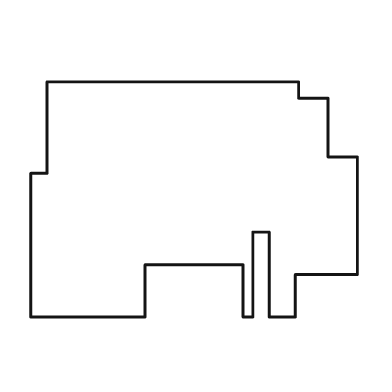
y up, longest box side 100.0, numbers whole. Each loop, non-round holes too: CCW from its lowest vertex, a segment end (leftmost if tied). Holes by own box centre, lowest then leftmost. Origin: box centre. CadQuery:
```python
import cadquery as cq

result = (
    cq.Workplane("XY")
    .moveTo(-50.0, -36.0)
    .lineTo(-15.0, -36.0)
    .lineTo(-15.0, -20.0)
    .lineTo(15.0, -20.0)
    .lineTo(15.0, -36.0)
    .lineTo(18.0, -36.0)
    .lineTo(18.0, -10.0)
    .lineTo(23.0, -10.0)
    .lineTo(23.0, -36.0)
    .lineTo(31.0, -36.0)
    .lineTo(31.0, -23.0)
    .lineTo(50.0, -23.0)
    .lineTo(50.0, 13.0)
    .lineTo(41.0, 13.0)
    .lineTo(41.0, 31.0)
    .lineTo(32.0, 31.0)
    .lineTo(32.0, 36.0)
    .lineTo(-45.0, 36.0)
    .lineTo(-45.0, 8.0)
    .lineTo(-50.0, 8.0)
    .close()
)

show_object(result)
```